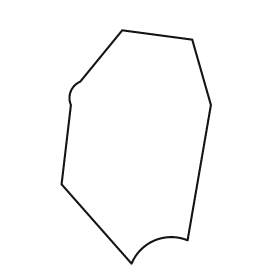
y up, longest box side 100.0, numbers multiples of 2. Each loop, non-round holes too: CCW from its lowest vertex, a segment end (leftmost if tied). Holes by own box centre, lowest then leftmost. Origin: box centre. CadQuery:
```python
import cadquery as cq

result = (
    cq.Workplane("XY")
    .moveTo(-2.0, -50.0)
    .threePointArc((8.0, -40.0), (22.0, -40.0))
    .lineTo(32.0, 18.0)
    .lineTo(24.0, 46.0)
    .lineTo(-6.0, 50.0)
    .lineTo(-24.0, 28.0)
    .threePointArc((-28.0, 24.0), (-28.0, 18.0))
    .lineTo(-32.0, -16.0)
    .close()
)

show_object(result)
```